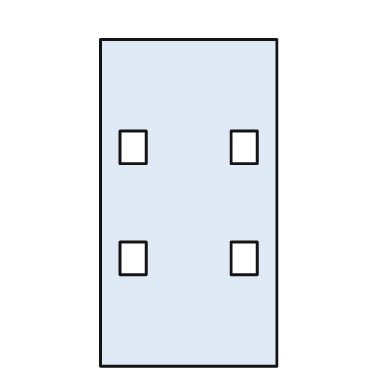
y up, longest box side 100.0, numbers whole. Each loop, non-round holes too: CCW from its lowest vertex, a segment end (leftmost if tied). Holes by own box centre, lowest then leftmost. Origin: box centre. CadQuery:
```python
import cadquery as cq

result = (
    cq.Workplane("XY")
    .moveTo(-27.0, -50.0)
    .lineTo(27.0, -50.0)
    .lineTo(27.0, 50.0)
    .lineTo(-27.0, 50.0)
    .close()
    .moveTo(-21.0, -22.0)
    .lineTo(-13.0, -22.0)
    .lineTo(-13.0, -12.0)
    .lineTo(-21.0, -12.0)
    .close()
    .moveTo(13.0, -22.0)
    .lineTo(21.0, -22.0)
    .lineTo(21.0, -12.0)
    .lineTo(13.0, -12.0)
    .close()
    .moveTo(-21.0, 12.0)
    .lineTo(-13.0, 12.0)
    .lineTo(-13.0, 22.0)
    .lineTo(-21.0, 22.0)
    .close()
    .moveTo(13.0, 12.0)
    .lineTo(21.0, 12.0)
    .lineTo(21.0, 22.0)
    .lineTo(13.0, 22.0)
    .close()
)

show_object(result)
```